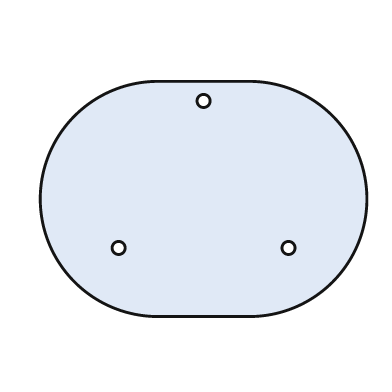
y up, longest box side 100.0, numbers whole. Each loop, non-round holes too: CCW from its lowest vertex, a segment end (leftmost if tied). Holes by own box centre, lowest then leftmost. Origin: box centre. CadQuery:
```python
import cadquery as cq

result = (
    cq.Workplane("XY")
    .moveTo(-14.0, -36.0)
    .lineTo(14.0, -36.0)
    .threePointArc((50.0, 0.0), (14.0, 36.0))
    .lineTo(-14.0, 36.0)
    .threePointArc((-50.0, 0.0), (-14.0, -36.0))
    .close()
    .moveTo(-26.0, -15.0)
    .circle(2.0)
    .moveTo(26.0, -15.0)
    .circle(2.0)
    .moveTo(0.0, 30.0)
    .circle(2.0)
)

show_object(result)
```